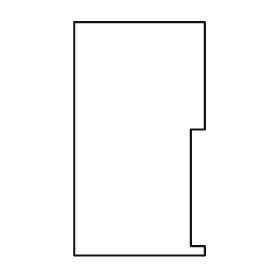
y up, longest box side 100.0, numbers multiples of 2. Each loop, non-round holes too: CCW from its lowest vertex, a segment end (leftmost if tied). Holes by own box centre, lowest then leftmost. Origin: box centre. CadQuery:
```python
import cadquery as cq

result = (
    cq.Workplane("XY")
    .moveTo(-28.0, -50.0)
    .lineTo(28.0, -50.0)
    .lineTo(28.0, -46.0)
    .lineTo(22.0, -46.0)
    .lineTo(22.0, 4.0)
    .lineTo(28.0, 4.0)
    .lineTo(28.0, 50.0)
    .lineTo(-28.0, 50.0)
    .close()
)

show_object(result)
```